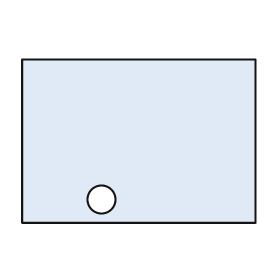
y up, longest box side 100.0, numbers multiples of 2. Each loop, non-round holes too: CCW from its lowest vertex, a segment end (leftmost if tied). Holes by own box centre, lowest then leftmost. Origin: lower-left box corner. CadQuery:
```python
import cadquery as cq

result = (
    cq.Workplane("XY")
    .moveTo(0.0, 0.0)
    .lineTo(100.0, 0.0)
    .lineTo(100.0, 70.0)
    .lineTo(0.0, 70.0)
    .close()
    .moveTo(34.0, 10.0)
    .circle(6.0)
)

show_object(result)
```